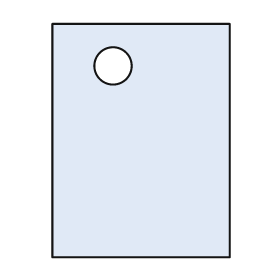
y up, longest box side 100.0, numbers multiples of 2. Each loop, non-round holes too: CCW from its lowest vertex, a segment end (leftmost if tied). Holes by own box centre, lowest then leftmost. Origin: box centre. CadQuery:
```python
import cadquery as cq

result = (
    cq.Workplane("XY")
    .moveTo(-38.0, -50.0)
    .lineTo(38.0, -50.0)
    .lineTo(38.0, 50.0)
    .lineTo(-38.0, 50.0)
    .close()
    .moveTo(-12.0, 32.0)
    .circle(8.0)
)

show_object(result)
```